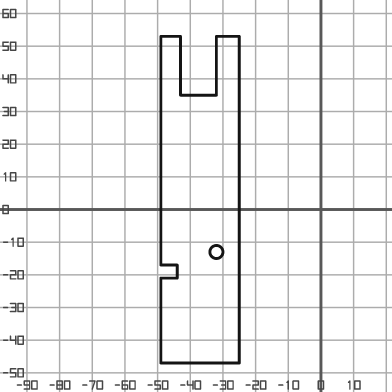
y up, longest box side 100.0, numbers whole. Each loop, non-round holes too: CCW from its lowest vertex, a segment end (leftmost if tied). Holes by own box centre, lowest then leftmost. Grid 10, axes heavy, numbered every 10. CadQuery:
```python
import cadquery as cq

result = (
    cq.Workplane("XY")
    .moveTo(-49.0, -47.0)
    .lineTo(-25.0, -47.0)
    .lineTo(-25.0, 53.0)
    .lineTo(-32.0, 53.0)
    .lineTo(-32.0, 35.0)
    .lineTo(-43.0, 35.0)
    .lineTo(-43.0, 53.0)
    .lineTo(-49.0, 53.0)
    .lineTo(-49.0, -17.0)
    .lineTo(-44.0, -17.0)
    .lineTo(-44.0, -21.0)
    .lineTo(-49.0, -21.0)
    .close()
    .moveTo(-32.0, -13.0)
    .circle(2.0)
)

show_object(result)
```